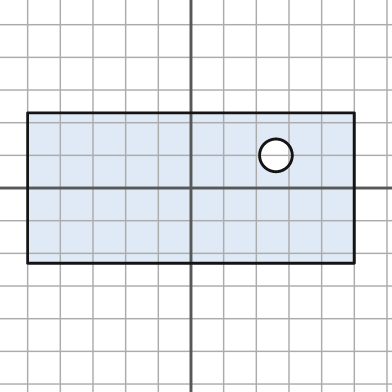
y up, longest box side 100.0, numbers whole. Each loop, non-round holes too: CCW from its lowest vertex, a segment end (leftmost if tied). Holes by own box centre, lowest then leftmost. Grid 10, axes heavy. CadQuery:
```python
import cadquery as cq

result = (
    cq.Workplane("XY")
    .moveTo(-50.0, -23.0)
    .lineTo(50.0, -23.0)
    .lineTo(50.0, 23.0)
    .lineTo(-50.0, 23.0)
    .close()
    .moveTo(26.0, 10.0)
    .circle(5.0)
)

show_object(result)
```